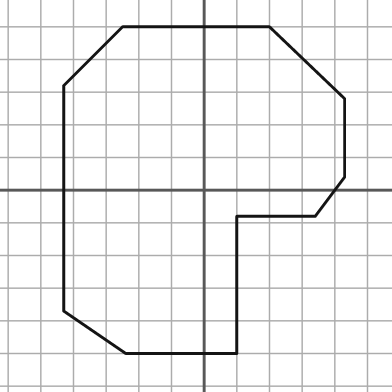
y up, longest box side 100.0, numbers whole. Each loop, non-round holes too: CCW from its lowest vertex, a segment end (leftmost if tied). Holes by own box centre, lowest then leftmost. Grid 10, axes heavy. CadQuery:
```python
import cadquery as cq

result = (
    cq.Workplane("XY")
    .moveTo(-24.0, -50.0)
    .lineTo(10.0, -50.0)
    .lineTo(10.0, -8.0)
    .lineTo(34.0, -8.0)
    .lineTo(43.0, 4.0)
    .lineTo(43.0, 28.0)
    .lineTo(20.0, 50.0)
    .lineTo(-25.0, 50.0)
    .lineTo(-43.0, 32.0)
    .lineTo(-43.0, -37.0)
    .close()
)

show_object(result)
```